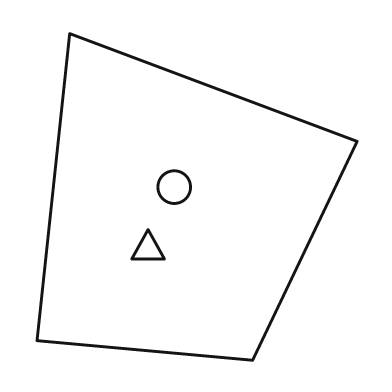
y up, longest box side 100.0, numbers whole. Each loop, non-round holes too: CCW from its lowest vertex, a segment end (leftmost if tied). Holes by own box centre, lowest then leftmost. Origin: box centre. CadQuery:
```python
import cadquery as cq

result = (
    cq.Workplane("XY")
    .moveTo(17.0, -50.0)
    .lineTo(49.0, 17.0)
    .lineTo(-39.0, 50.0)
    .lineTo(-49.0, -44.0)
    .close()
    .moveTo(-20.0, -19.0)
    .lineTo(-10.0, -19.0)
    .lineTo(-15.0, -10.0)
    .close()
    .moveTo(-7.0, 3.0)
    .circle(5.0)
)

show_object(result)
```